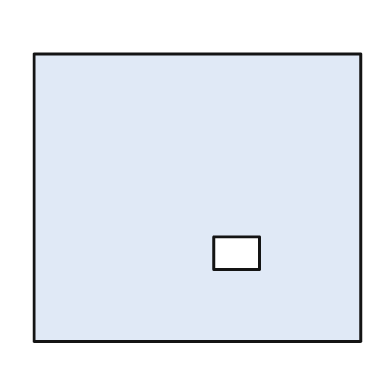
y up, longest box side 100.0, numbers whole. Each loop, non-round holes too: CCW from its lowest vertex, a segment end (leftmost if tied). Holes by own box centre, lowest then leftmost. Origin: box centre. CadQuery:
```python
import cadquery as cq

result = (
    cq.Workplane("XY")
    .moveTo(-50.0, -44.0)
    .lineTo(50.0, -44.0)
    .lineTo(50.0, 44.0)
    .lineTo(-50.0, 44.0)
    .close()
    .moveTo(5.0, -22.0)
    .lineTo(19.0, -22.0)
    .lineTo(19.0, -12.0)
    .lineTo(5.0, -12.0)
    .close()
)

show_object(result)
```